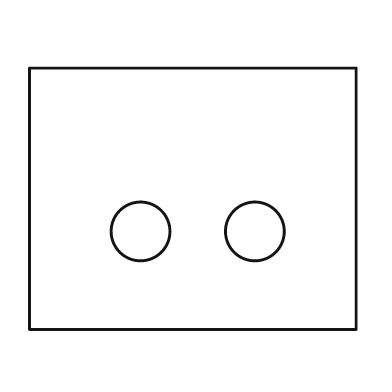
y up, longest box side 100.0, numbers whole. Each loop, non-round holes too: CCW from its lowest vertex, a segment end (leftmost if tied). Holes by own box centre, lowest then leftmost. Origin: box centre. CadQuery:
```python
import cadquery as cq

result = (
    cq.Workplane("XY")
    .moveTo(-50.0, -40.0)
    .lineTo(50.0, -40.0)
    .lineTo(50.0, 40.0)
    .lineTo(-50.0, 40.0)
    .close()
    .moveTo(-16.0, -10.0)
    .circle(9.0)
    .moveTo(19.0, -10.0)
    .circle(9.0)
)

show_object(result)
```